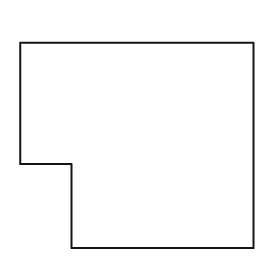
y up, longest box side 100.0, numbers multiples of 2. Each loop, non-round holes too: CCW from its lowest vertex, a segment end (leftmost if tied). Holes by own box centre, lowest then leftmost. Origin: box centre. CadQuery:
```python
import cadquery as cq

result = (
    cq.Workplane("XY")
    .moveTo(-28.0, -44.0)
    .lineTo(50.0, -44.0)
    .lineTo(50.0, 44.0)
    .lineTo(-50.0, 44.0)
    .lineTo(-50.0, -8.0)
    .lineTo(-28.0, -8.0)
    .close()
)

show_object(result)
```